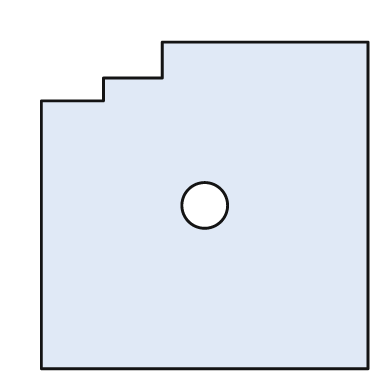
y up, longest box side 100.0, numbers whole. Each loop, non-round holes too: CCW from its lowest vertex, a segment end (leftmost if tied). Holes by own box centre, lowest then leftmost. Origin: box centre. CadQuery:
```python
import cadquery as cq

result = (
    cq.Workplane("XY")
    .moveTo(-50.0, -50.0)
    .lineTo(50.0, -50.0)
    .lineTo(50.0, 50.0)
    .lineTo(-13.0, 50.0)
    .lineTo(-13.0, 39.0)
    .lineTo(-31.0, 39.0)
    .lineTo(-31.0, 32.0)
    .lineTo(-50.0, 32.0)
    .close()
    .moveTo(0.0, 0.0)
    .circle(7.0)
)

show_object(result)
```